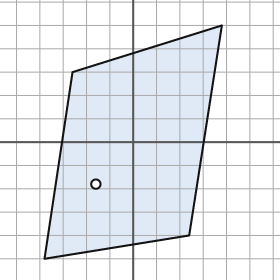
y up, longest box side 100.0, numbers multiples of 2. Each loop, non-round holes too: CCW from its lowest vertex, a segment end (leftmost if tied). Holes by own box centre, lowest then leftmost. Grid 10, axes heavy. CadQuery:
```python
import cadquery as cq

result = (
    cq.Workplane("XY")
    .moveTo(-38.0, -50.0)
    .lineTo(24.0, -40.0)
    .lineTo(38.0, 50.0)
    .lineTo(-26.0, 30.0)
    .close()
    .moveTo(-16.0, -18.0)
    .circle(2.0)
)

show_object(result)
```